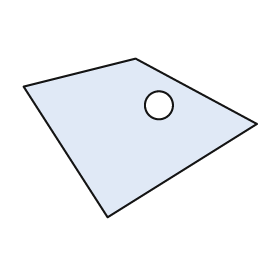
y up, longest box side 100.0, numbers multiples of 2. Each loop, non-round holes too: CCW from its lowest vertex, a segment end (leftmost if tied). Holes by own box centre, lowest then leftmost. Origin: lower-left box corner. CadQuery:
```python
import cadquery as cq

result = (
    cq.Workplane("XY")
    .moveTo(36.0, 0.0)
    .lineTo(100.0, 40.0)
    .lineTo(48.0, 68.0)
    .lineTo(0.0, 56.0)
    .close()
    .moveTo(58.0, 48.0)
    .circle(6.0)
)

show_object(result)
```